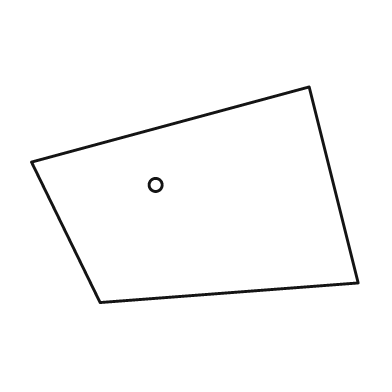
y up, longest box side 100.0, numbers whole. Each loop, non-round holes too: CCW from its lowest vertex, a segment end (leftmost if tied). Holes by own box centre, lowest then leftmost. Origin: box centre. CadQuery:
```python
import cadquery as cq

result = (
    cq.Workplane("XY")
    .moveTo(-29.0, -33.0)
    .lineTo(50.0, -27.0)
    .lineTo(35.0, 33.0)
    .lineTo(-50.0, 10.0)
    .close()
    .moveTo(-12.0, 3.0)
    .circle(2.0)
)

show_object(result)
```